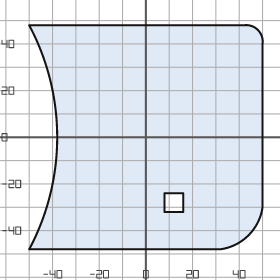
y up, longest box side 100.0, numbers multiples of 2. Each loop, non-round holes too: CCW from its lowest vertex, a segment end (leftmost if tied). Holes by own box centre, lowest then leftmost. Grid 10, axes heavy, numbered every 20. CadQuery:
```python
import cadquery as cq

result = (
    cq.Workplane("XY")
    .moveTo(-50.0, -48.0)
    .lineTo(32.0, -48.0)
    .threePointArc((44.0, -42.0), (50.0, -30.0))
    .lineTo(50.0, 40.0)
    .threePointArc((48.0, 46.0), (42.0, 48.0))
    .lineTo(-50.0, 48.0)
    .threePointArc((-38.0, 0.0), (-50.0, -48.0))
    .close()
    .moveTo(8.0, -32.0)
    .lineTo(16.0, -32.0)
    .lineTo(16.0, -24.0)
    .lineTo(8.0, -24.0)
    .close()
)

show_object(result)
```